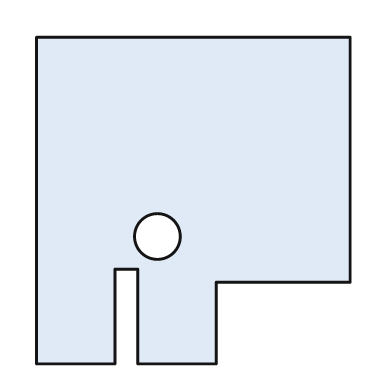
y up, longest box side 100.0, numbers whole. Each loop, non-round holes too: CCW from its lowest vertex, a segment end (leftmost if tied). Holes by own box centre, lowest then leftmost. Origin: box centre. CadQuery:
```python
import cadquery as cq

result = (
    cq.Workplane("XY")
    .moveTo(-48.0, -50.0)
    .lineTo(-24.0, -50.0)
    .lineTo(-24.0, -21.0)
    .lineTo(-17.0, -21.0)
    .lineTo(-17.0, -50.0)
    .lineTo(7.0, -50.0)
    .lineTo(7.0, -25.0)
    .lineTo(48.0, -25.0)
    .lineTo(48.0, 50.0)
    .lineTo(-48.0, 50.0)
    .close()
    .moveTo(-11.0, -11.0)
    .circle(7.0)
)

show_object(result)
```